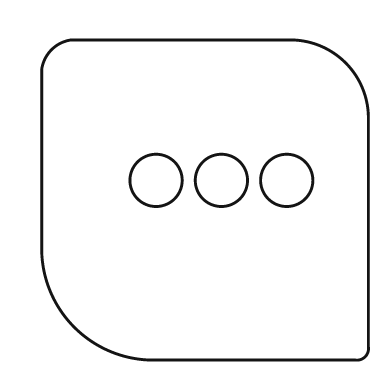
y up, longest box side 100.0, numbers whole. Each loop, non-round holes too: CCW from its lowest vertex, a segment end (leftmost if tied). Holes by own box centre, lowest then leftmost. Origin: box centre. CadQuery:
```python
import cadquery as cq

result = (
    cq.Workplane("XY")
    .moveTo(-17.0, -49.0)
    .lineTo(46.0, -49.0)
    .threePointArc((49.0, -48.0), (50.0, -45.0))
    .lineTo(50.0, 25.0)
    .threePointArc((43.0, 42.0), (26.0, 49.0))
    .lineTo(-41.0, 49.0)
    .threePointArc((-47.0, 46.0), (-50.0, 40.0))
    .lineTo(-50.0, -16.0)
    .threePointArc((-40.0, -39.0), (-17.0, -49.0))
    .close()
    .moveTo(-15.0, 6.0)
    .circle(8.0)
    .moveTo(5.0, 6.0)
    .circle(8.0)
    .moveTo(25.0, 6.0)
    .circle(8.0)
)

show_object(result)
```